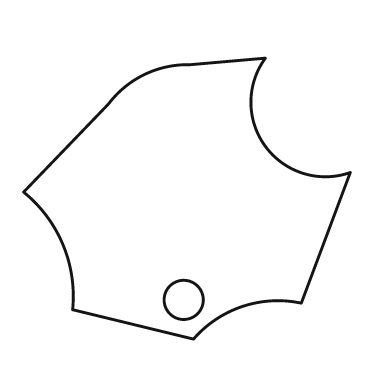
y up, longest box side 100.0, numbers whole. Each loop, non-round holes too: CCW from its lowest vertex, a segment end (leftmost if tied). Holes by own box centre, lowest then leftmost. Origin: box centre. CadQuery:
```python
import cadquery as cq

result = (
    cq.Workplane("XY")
    .moveTo(2.0, -43.0)
    .threePointArc((17.0, -33.0), (35.0, -32.0))
    .lineTo(50.0, 8.0)
    .threePointArc((24.0, 16.0), (24.0, 43.0))
    .lineTo(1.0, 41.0)
    .threePointArc((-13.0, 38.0), (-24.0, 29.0))
    .lineTo(-50.0, 2.0)
    .threePointArc((-38.0, -14.0), (-35.0, -34.0))
    .close()
    .moveTo(-1.0, -31.0)
    .circle(6.0)
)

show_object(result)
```